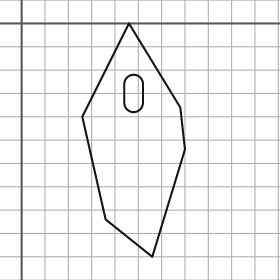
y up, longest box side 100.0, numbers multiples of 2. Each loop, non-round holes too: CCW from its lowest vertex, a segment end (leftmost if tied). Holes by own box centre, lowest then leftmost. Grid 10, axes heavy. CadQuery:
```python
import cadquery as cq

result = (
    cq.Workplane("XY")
    .moveTo(56.0, -100.0)
    .lineTo(70.0, -54.0)
    .lineTo(68.0, -36.0)
    .lineTo(46.0, 0.0)
    .lineTo(26.0, -40.0)
    .lineTo(36.0, -84.0)
    .close()
    .moveTo(44.0, -34.0)
    .threePointArc((48.0, -38.0), (52.0, -34.0))
    .lineTo(52.0, -26.0)
    .threePointArc((48.0, -22.0), (44.0, -26.0))
    .close()
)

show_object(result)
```